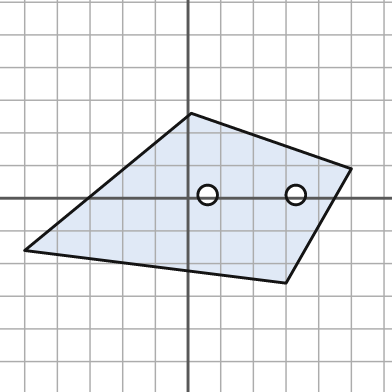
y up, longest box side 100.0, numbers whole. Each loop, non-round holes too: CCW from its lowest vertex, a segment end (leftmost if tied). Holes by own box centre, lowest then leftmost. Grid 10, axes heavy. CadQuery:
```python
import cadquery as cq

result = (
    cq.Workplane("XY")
    .moveTo(30.0, -26.0)
    .lineTo(50.0, 9.0)
    .lineTo(1.0, 26.0)
    .lineTo(-50.0, -16.0)
    .close()
    .moveTo(6.0, 1.0)
    .circle(3.0)
    .moveTo(33.0, 1.0)
    .circle(3.0)
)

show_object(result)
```